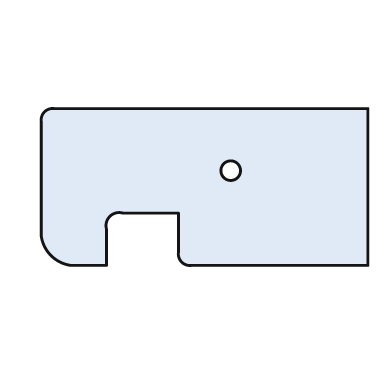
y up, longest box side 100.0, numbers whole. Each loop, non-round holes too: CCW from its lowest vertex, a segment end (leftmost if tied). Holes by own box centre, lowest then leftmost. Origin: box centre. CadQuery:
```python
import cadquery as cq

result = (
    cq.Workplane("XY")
    .moveTo(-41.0, -24.0)
    .lineTo(-30.0, -24.0)
    .lineTo(-30.0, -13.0)
    .threePointArc((-29.0, -9.0), (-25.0, -8.0))
    .lineTo(-8.0, -8.0)
    .lineTo(-8.0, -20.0)
    .threePointArc((-7.0, -23.0), (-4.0, -24.0))
    .lineTo(50.0, -24.0)
    .lineTo(50.0, 24.0)
    .lineTo(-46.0, 24.0)
    .threePointArc((-49.0, 23.0), (-50.0, 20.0))
    .lineTo(-50.0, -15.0)
    .threePointArc((-47.0, -21.0), (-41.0, -24.0))
    .close()
    .moveTo(8.0, 5.0)
    .circle(3.0)
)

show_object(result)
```